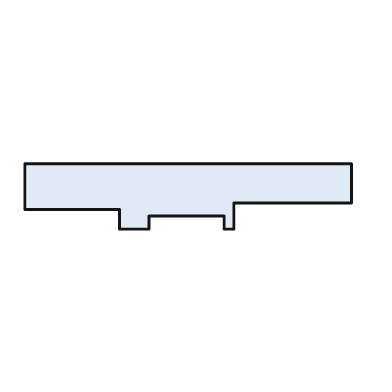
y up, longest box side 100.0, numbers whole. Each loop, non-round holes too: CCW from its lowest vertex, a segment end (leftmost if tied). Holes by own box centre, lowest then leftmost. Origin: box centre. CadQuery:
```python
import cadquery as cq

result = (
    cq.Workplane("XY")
    .moveTo(-21.0, -10.0)
    .lineTo(-12.0, -10.0)
    .lineTo(-12.0, -6.0)
    .lineTo(11.0, -6.0)
    .lineTo(11.0, -10.0)
    .lineTo(14.0, -10.0)
    .lineTo(14.0, -2.0)
    .lineTo(50.0, -2.0)
    .lineTo(50.0, 10.0)
    .lineTo(-50.0, 10.0)
    .lineTo(-50.0, -4.0)
    .lineTo(-21.0, -4.0)
    .close()
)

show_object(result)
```